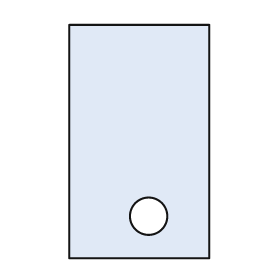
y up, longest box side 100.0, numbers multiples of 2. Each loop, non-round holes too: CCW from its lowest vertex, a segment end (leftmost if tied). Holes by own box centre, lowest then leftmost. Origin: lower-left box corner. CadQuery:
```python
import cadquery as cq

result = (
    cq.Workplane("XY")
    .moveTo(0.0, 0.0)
    .lineTo(60.0, 0.0)
    .lineTo(60.0, 100.0)
    .lineTo(0.0, 100.0)
    .close()
    .moveTo(34.0, 18.0)
    .circle(8.0)
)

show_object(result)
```